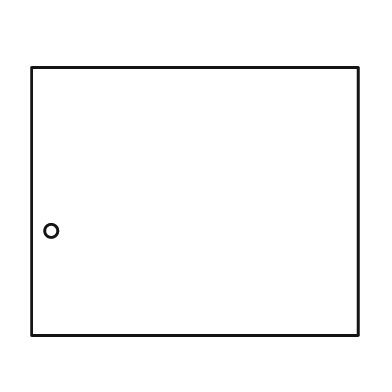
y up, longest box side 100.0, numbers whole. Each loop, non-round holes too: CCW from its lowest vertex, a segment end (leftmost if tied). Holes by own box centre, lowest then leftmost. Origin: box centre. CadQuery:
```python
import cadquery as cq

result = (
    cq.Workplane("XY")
    .moveTo(-50.0, -41.0)
    .lineTo(50.0, -41.0)
    .lineTo(50.0, 41.0)
    .lineTo(-50.0, 41.0)
    .close()
    .moveTo(-44.0, -9.0)
    .circle(2.0)
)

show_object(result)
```